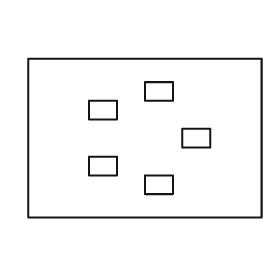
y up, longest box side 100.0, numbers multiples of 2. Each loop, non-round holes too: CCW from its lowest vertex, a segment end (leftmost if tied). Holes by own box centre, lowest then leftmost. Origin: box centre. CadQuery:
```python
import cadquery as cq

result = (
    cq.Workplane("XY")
    .moveTo(-50.0, -34.0)
    .lineTo(50.0, -34.0)
    .lineTo(50.0, 34.0)
    .lineTo(-50.0, 34.0)
    .close()
    .moveTo(0.0, -24.0)
    .lineTo(12.0, -24.0)
    .lineTo(12.0, -16.0)
    .lineTo(0.0, -16.0)
    .close()
    .moveTo(-24.0, -16.0)
    .lineTo(-12.0, -16.0)
    .lineTo(-12.0, -8.0)
    .lineTo(-24.0, -8.0)
    .close()
    .moveTo(16.0, -4.0)
    .lineTo(28.0, -4.0)
    .lineTo(28.0, 4.0)
    .lineTo(16.0, 4.0)
    .close()
    .moveTo(-24.0, 8.0)
    .lineTo(-12.0, 8.0)
    .lineTo(-12.0, 16.0)
    .lineTo(-24.0, 16.0)
    .close()
    .moveTo(0.0, 16.0)
    .lineTo(12.0, 16.0)
    .lineTo(12.0, 24.0)
    .lineTo(0.0, 24.0)
    .close()
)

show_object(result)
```